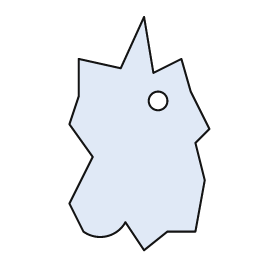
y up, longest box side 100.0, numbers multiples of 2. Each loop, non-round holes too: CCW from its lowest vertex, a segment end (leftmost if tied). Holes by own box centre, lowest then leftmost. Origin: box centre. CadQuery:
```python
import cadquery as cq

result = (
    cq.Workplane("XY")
    .moveTo(2.0, -50.0)
    .lineTo(12.0, -42.0)
    .lineTo(24.0, -42.0)
    .lineTo(28.0, -20.0)
    .lineTo(24.0, -4.0)
    .lineTo(30.0, 2.0)
    .lineTo(22.0, 18.0)
    .lineTo(18.0, 32.0)
    .lineTo(6.0, 26.0)
    .lineTo(2.0, 50.0)
    .lineTo(-8.0, 28.0)
    .lineTo(-26.0, 32.0)
    .lineTo(-26.0, 16.0)
    .lineTo(-30.0, 4.0)
    .lineTo(-20.0, -10.0)
    .lineTo(-30.0, -30.0)
    .lineTo(-24.0, -42.0)
    .threePointArc((-14.0, -44.0), (-6.0, -38.0))
    .close()
    .moveTo(8.0, 14.0)
    .circle(4.0)
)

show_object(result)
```